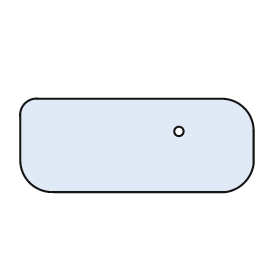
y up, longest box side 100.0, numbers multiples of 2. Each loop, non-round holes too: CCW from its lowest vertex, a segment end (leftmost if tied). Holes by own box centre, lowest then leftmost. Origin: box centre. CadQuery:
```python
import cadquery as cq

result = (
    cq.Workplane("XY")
    .moveTo(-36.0, -20.0)
    .lineTo(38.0, -20.0)
    .threePointArc((46.0, -16.0), (50.0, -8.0))
    .lineTo(50.0, 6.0)
    .threePointArc((46.0, 16.0), (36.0, 20.0))
    .lineTo(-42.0, 20.0)
    .threePointArc((-48.0, 18.0), (-50.0, 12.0))
    .lineTo(-50.0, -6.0)
    .threePointArc((-46.0, -16.0), (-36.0, -20.0))
    .close()
    .moveTo(18.0, 6.0)
    .circle(2.0)
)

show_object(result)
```